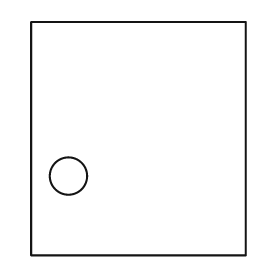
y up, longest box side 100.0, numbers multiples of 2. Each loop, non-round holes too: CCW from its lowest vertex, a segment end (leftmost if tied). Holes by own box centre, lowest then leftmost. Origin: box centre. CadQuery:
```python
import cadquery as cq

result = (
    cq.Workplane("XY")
    .moveTo(-46.0, -50.0)
    .lineTo(46.0, -50.0)
    .lineTo(46.0, 50.0)
    .lineTo(-46.0, 50.0)
    .close()
    .moveTo(-30.0, -16.0)
    .circle(8.0)
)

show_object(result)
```